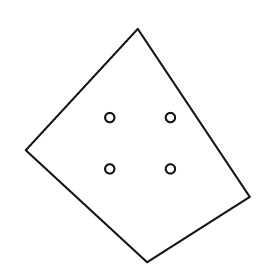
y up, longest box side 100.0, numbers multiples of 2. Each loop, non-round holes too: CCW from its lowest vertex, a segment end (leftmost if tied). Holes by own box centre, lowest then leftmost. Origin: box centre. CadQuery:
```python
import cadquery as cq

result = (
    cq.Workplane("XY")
    .moveTo(4.0, -50.0)
    .lineTo(48.0, -22.0)
    .lineTo(0.0, 50.0)
    .lineTo(-48.0, -2.0)
    .close()
    .moveTo(-12.0, -10.0)
    .circle(2.0)
    .moveTo(14.0, -10.0)
    .circle(2.0)
    .moveTo(-12.0, 12.0)
    .circle(2.0)
    .moveTo(14.0, 12.0)
    .circle(2.0)
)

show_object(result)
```